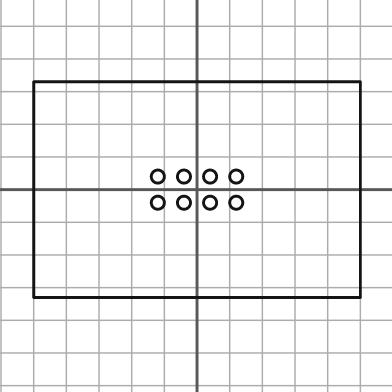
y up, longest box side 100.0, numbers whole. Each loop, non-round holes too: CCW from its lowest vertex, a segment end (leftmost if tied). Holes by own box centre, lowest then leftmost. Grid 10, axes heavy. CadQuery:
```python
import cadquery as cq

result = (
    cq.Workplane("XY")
    .moveTo(-50.0, -33.0)
    .lineTo(50.0, -33.0)
    .lineTo(50.0, 33.0)
    .lineTo(-50.0, 33.0)
    .close()
    .moveTo(-12.0, -4.0)
    .circle(2.0)
    .moveTo(-4.0, -4.0)
    .circle(2.0)
    .moveTo(4.0, -4.0)
    .circle(2.0)
    .moveTo(12.0, -4.0)
    .circle(2.0)
    .moveTo(-12.0, 4.0)
    .circle(2.0)
    .moveTo(-4.0, 4.0)
    .circle(2.0)
    .moveTo(4.0, 4.0)
    .circle(2.0)
    .moveTo(12.0, 4.0)
    .circle(2.0)
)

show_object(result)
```